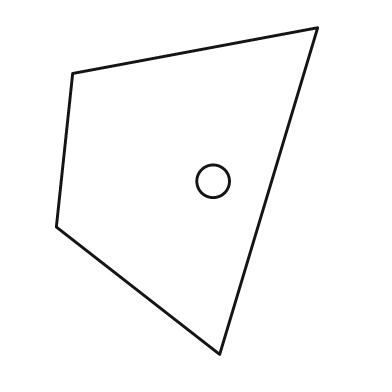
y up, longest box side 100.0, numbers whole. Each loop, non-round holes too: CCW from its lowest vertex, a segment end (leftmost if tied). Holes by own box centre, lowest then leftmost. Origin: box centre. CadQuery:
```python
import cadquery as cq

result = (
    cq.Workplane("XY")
    .moveTo(10.0, -50.0)
    .lineTo(40.0, 50.0)
    .lineTo(-35.0, 36.0)
    .lineTo(-40.0, -11.0)
    .close()
    .moveTo(8.0, 3.0)
    .circle(5.0)
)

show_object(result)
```